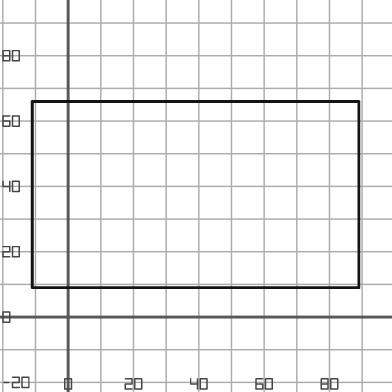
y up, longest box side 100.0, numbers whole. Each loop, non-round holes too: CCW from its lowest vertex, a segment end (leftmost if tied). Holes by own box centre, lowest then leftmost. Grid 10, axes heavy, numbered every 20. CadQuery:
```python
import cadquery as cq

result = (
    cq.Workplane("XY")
    .moveTo(-11.0, 9.0)
    .lineTo(89.0, 9.0)
    .lineTo(89.0, 66.0)
    .lineTo(-11.0, 66.0)
    .close()
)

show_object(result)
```